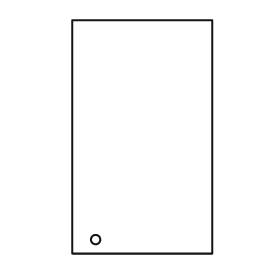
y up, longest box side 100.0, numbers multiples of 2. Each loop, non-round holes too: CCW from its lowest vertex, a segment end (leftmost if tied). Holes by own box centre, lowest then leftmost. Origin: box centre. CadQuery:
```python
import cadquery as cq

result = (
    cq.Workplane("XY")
    .moveTo(-30.0, -50.0)
    .lineTo(30.0, -50.0)
    .lineTo(30.0, 50.0)
    .lineTo(-30.0, 50.0)
    .close()
    .moveTo(-20.0, -44.0)
    .circle(2.0)
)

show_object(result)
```